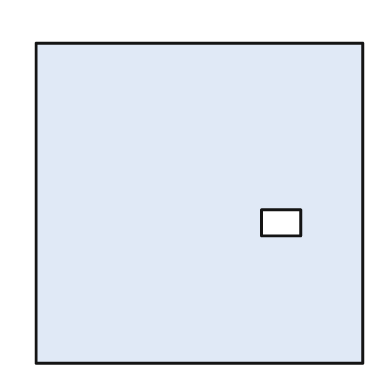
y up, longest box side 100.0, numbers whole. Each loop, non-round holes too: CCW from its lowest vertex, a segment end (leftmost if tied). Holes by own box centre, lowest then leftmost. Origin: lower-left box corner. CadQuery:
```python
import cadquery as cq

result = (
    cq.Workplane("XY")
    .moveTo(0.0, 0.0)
    .lineTo(100.0, 0.0)
    .lineTo(100.0, 98.0)
    .lineTo(0.0, 98.0)
    .close()
    .moveTo(69.0, 39.0)
    .lineTo(81.0, 39.0)
    .lineTo(81.0, 47.0)
    .lineTo(69.0, 47.0)
    .close()
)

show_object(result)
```